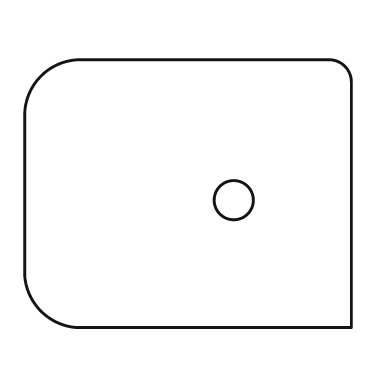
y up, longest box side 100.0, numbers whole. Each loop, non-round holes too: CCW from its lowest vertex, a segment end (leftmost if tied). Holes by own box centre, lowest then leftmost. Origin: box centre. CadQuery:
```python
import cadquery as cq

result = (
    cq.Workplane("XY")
    .moveTo(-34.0, -41.0)
    .lineTo(50.0, -41.0)
    .lineTo(50.0, 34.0)
    .threePointArc((48.0, 39.0), (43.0, 41.0))
    .lineTo(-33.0, 41.0)
    .threePointArc((-45.0, 36.0), (-50.0, 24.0))
    .lineTo(-50.0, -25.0)
    .threePointArc((-45.0, -36.0), (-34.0, -41.0))
    .close()
    .moveTo(14.0, -2.0)
    .circle(6.0)
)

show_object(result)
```